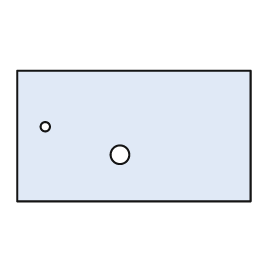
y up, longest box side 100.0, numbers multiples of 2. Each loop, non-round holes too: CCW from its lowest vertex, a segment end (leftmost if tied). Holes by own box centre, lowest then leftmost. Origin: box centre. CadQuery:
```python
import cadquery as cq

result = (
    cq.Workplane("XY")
    .moveTo(-50.0, -28.0)
    .lineTo(50.0, -28.0)
    .lineTo(50.0, 28.0)
    .lineTo(-50.0, 28.0)
    .close()
    .moveTo(-6.0, -8.0)
    .circle(4.0)
    .moveTo(-38.0, 4.0)
    .circle(2.0)
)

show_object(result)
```